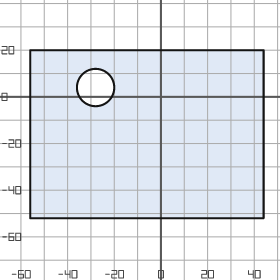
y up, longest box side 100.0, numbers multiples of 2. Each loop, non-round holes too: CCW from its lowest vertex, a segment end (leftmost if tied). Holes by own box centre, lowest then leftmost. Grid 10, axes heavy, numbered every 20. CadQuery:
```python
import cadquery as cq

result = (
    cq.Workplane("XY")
    .moveTo(-56.0, -52.0)
    .lineTo(44.0, -52.0)
    .lineTo(44.0, 20.0)
    .lineTo(-56.0, 20.0)
    .close()
    .moveTo(-28.0, 4.0)
    .circle(8.0)
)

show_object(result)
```